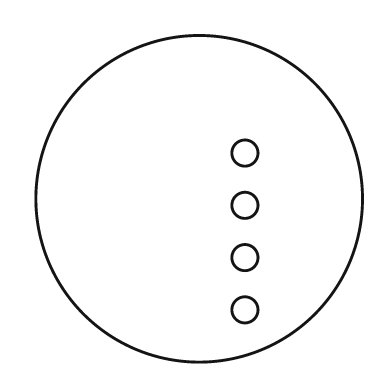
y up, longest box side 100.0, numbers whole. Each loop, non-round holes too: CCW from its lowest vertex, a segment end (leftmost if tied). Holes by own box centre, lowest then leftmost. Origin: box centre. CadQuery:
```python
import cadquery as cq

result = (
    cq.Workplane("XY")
    .moveTo(0.0, 0.0)
    .circle(50.0)
    .moveTo(14.0, -34.0)
    .circle(4.0)
    .moveTo(14.0, -18.0)
    .circle(4.0)
    .moveTo(14.0, -2.0)
    .circle(4.0)
    .moveTo(14.0, 14.0)
    .circle(4.0)
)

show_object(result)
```